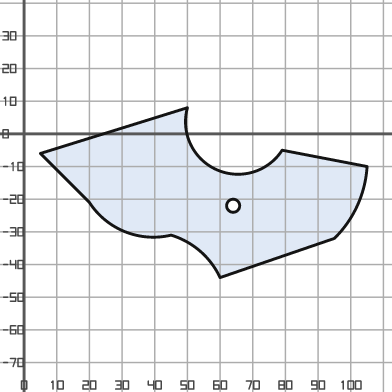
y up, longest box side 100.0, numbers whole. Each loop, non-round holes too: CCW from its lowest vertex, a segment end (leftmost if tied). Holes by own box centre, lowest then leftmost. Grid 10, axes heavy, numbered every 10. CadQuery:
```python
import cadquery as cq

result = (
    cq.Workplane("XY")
    .moveTo(60.0, -44.0)
    .lineTo(95.0, -32.0)
    .threePointArc((102.0, -22.0), (105.0, -10.0))
    .lineTo(79.0, -5.0)
    .threePointArc((59.0, -11.0), (50.0, 8.0))
    .lineTo(5.0, -6.0)
    .lineTo(20.0, -21.0)
    .threePointArc((31.0, -30.0), (45.0, -31.0))
    .threePointArc((54.0, -36.0), (60.0, -44.0))
    .close()
    .moveTo(64.0, -22.0)
    .circle(2.0)
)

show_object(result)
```